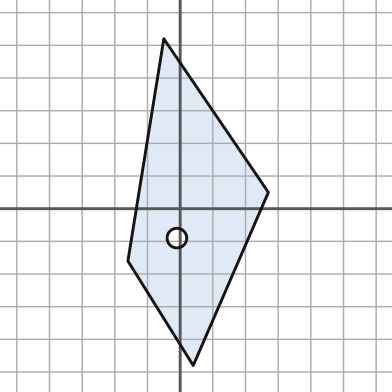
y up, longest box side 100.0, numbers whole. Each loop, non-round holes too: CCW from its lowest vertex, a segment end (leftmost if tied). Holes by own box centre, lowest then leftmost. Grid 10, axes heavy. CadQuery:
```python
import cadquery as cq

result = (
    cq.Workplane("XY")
    .moveTo(4.0, -48.0)
    .lineTo(27.0, 5.0)
    .lineTo(-5.0, 52.0)
    .lineTo(-16.0, -16.0)
    .close()
    .moveTo(-1.0, -9.0)
    .circle(3.0)
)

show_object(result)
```